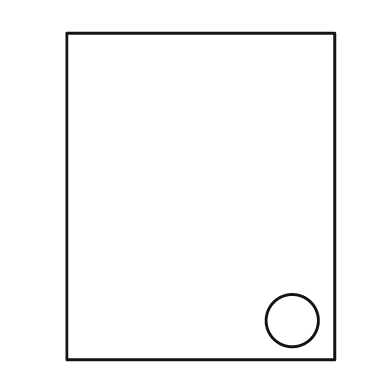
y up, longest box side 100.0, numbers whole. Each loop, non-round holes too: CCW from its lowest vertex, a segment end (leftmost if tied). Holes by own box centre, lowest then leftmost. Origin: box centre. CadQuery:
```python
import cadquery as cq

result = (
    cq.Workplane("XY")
    .moveTo(-41.0, -50.0)
    .lineTo(41.0, -50.0)
    .lineTo(41.0, 50.0)
    .lineTo(-41.0, 50.0)
    .close()
    .moveTo(28.0, -38.0)
    .circle(8.0)
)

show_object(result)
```